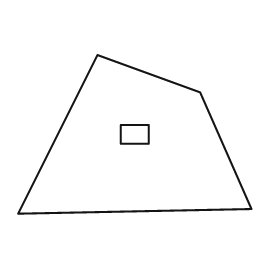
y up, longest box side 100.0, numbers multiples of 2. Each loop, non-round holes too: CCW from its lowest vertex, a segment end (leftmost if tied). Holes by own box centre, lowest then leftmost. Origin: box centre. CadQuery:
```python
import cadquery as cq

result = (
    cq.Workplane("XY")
    .moveTo(-50.0, -34.0)
    .lineTo(50.0, -32.0)
    .lineTo(28.0, 18.0)
    .lineTo(-16.0, 34.0)
    .close()
    .moveTo(-6.0, -4.0)
    .lineTo(6.0, -4.0)
    .lineTo(6.0, 4.0)
    .lineTo(-6.0, 4.0)
    .close()
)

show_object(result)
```